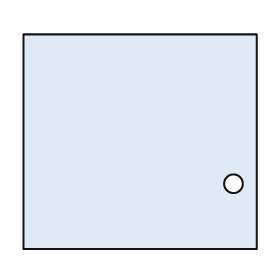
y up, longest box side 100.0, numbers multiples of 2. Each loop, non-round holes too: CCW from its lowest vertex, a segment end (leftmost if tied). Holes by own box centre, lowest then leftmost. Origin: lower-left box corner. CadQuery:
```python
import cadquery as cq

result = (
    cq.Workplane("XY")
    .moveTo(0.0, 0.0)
    .lineTo(100.0, 0.0)
    .lineTo(100.0, 92.0)
    .lineTo(0.0, 92.0)
    .close()
    .moveTo(90.0, 28.0)
    .circle(4.0)
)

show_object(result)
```